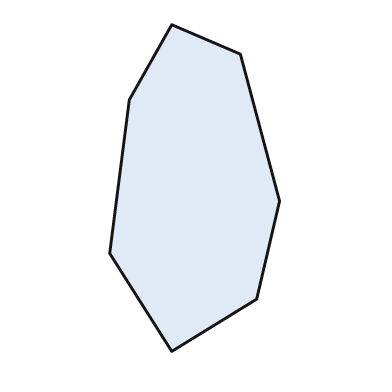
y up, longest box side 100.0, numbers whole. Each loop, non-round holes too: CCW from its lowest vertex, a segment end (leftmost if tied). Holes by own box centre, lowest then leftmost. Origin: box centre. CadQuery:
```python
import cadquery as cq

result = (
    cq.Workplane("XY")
    .moveTo(-7.0, -50.0)
    .lineTo(19.0, -34.0)
    .lineTo(26.0, -4.0)
    .lineTo(14.0, 41.0)
    .lineTo(-7.0, 50.0)
    .lineTo(-20.0, 27.0)
    .lineTo(-26.0, -20.0)
    .close()
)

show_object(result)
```